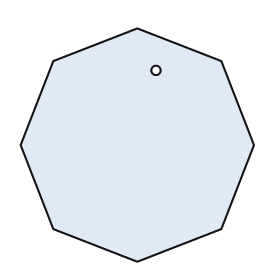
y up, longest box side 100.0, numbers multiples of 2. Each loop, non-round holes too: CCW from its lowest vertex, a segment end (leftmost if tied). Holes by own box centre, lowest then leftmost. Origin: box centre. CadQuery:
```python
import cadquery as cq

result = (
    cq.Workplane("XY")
    .moveTo(0.0, -50.0)
    .lineTo(36.0, -36.0)
    .lineTo(50.0, 0.0)
    .lineTo(36.0, 36.0)
    .lineTo(0.0, 50.0)
    .lineTo(-36.0, 36.0)
    .lineTo(-50.0, 0.0)
    .lineTo(-36.0, -36.0)
    .close()
    .moveTo(8.0, 32.0)
    .circle(2.0)
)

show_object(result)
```